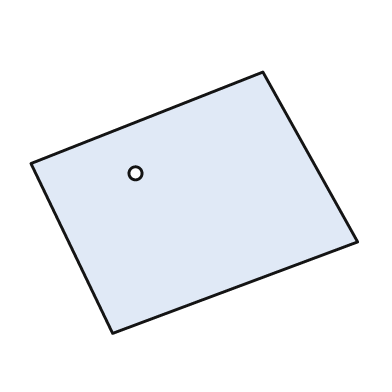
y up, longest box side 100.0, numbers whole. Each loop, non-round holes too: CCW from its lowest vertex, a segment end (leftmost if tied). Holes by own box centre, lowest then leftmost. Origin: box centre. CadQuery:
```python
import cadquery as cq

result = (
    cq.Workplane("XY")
    .moveTo(-25.0, -40.0)
    .lineTo(50.0, -12.0)
    .lineTo(21.0, 40.0)
    .lineTo(-50.0, 12.0)
    .close()
    .moveTo(-18.0, 9.0)
    .circle(2.0)
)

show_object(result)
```